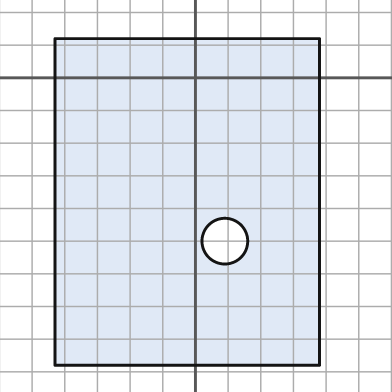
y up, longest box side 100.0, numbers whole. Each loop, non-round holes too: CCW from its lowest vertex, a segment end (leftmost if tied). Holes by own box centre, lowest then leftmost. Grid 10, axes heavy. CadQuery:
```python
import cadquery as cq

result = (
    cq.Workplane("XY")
    .moveTo(-43.0, -88.0)
    .lineTo(38.0, -88.0)
    .lineTo(38.0, 12.0)
    .lineTo(-43.0, 12.0)
    .close()
    .moveTo(9.0, -50.0)
    .circle(7.0)
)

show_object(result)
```